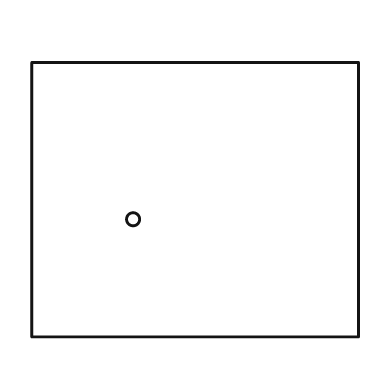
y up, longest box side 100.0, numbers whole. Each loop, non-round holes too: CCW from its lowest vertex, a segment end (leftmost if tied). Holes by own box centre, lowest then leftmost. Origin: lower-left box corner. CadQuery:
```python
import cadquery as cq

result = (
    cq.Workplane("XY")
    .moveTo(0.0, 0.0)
    .lineTo(100.0, 0.0)
    .lineTo(100.0, 84.0)
    .lineTo(0.0, 84.0)
    .close()
    .moveTo(31.0, 36.0)
    .circle(2.0)
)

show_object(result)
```